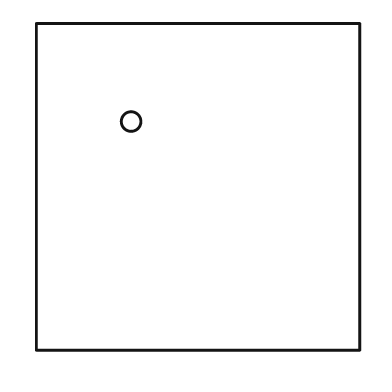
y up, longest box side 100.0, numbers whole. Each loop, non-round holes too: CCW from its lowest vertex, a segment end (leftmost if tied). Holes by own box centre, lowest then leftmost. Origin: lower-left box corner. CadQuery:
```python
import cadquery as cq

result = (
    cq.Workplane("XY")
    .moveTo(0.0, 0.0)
    .lineTo(99.0, 0.0)
    .lineTo(99.0, 100.0)
    .lineTo(0.0, 100.0)
    .close()
    .moveTo(29.0, 70.0)
    .circle(3.0)
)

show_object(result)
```